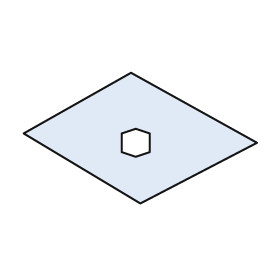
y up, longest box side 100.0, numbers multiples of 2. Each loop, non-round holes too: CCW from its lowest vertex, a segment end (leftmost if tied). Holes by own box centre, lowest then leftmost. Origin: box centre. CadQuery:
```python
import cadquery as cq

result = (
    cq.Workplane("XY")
    .moveTo(0.0, -28.0)
    .lineTo(50.0, -2.0)
    .lineTo(-4.0, 28.0)
    .lineTo(-50.0, 2.0)
    .close()
    .moveTo(-2.0, -8.0)
    .lineTo(4.0, -6.0)
    .lineTo(4.0, 2.0)
    .lineTo(-2.0, 4.0)
    .lineTo(-8.0, 2.0)
    .lineTo(-8.0, -6.0)
    .close()
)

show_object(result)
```